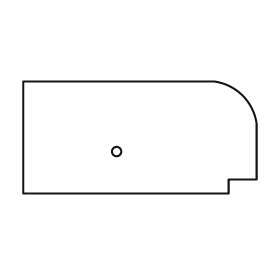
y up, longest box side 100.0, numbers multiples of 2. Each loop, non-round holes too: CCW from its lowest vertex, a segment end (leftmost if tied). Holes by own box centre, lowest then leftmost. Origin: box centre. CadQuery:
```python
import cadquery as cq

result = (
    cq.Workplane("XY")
    .moveTo(-50.0, -24.0)
    .lineTo(38.0, -24.0)
    .lineTo(38.0, -18.0)
    .lineTo(50.0, -18.0)
    .lineTo(50.0, 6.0)
    .threePointArc((44.0, 18.0), (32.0, 24.0))
    .lineTo(-50.0, 24.0)
    .close()
    .moveTo(-10.0, -6.0)
    .circle(2.0)
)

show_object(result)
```